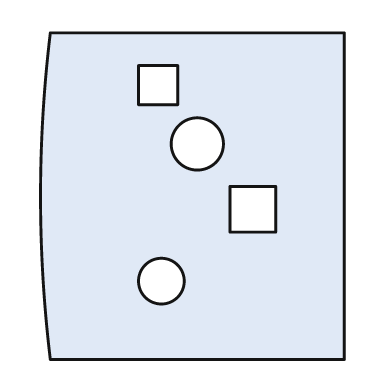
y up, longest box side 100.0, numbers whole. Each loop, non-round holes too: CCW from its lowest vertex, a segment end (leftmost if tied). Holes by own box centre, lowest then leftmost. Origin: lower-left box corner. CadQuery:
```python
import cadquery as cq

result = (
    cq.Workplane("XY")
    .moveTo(3.0, 0.0)
    .lineTo(93.0, 0.0)
    .lineTo(93.0, 100.0)
    .lineTo(3.0, 100.0)
    .threePointArc((0.0, 50.0), (3.0, 0.0))
    .close()
    .moveTo(37.0, 24.0)
    .circle(7.0)
    .moveTo(58.0, 39.0)
    .lineTo(72.0, 39.0)
    .lineTo(72.0, 53.0)
    .lineTo(58.0, 53.0)
    .close()
    .moveTo(48.0, 66.0)
    .circle(8.0)
    .moveTo(30.0, 78.0)
    .lineTo(42.0, 78.0)
    .lineTo(42.0, 90.0)
    .lineTo(30.0, 90.0)
    .close()
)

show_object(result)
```